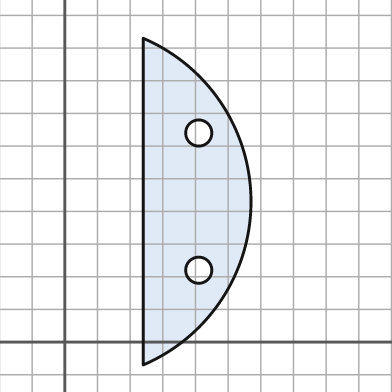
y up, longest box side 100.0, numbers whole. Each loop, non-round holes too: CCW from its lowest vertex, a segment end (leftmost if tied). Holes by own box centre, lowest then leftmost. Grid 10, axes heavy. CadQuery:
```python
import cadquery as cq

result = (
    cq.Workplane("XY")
    .moveTo(24.0, -7.0)
    .threePointArc((57.0, 43.0), (24.0, 93.0))
    .close()
    .moveTo(41.0, 22.0)
    .circle(4.0)
    .moveTo(41.0, 64.0)
    .circle(4.0)
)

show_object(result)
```